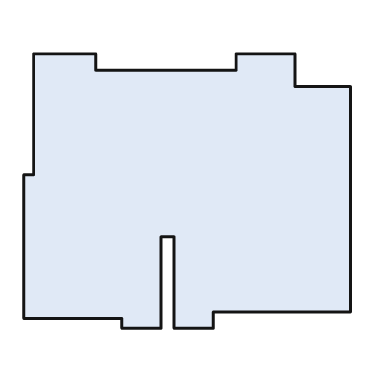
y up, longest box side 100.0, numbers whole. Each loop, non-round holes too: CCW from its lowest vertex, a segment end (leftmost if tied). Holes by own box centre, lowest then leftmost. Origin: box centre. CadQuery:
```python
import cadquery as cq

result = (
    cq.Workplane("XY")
    .moveTo(-20.0, -42.0)
    .lineTo(-8.0, -42.0)
    .lineTo(-8.0, -14.0)
    .lineTo(-4.0, -14.0)
    .lineTo(-4.0, -42.0)
    .lineTo(8.0, -42.0)
    .lineTo(8.0, -37.0)
    .lineTo(50.0, -37.0)
    .lineTo(50.0, 32.0)
    .lineTo(33.0, 32.0)
    .lineTo(33.0, 42.0)
    .lineTo(15.0, 42.0)
    .lineTo(15.0, 37.0)
    .lineTo(-28.0, 37.0)
    .lineTo(-28.0, 42.0)
    .lineTo(-47.0, 42.0)
    .lineTo(-47.0, 5.0)
    .lineTo(-50.0, 5.0)
    .lineTo(-50.0, -39.0)
    .lineTo(-20.0, -39.0)
    .close()
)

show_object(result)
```